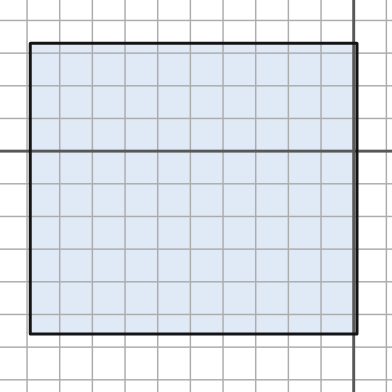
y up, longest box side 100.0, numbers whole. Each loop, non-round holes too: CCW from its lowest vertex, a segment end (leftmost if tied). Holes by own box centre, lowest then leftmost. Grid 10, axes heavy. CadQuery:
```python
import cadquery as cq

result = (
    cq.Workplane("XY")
    .moveTo(-99.0, -56.0)
    .lineTo(1.0, -56.0)
    .lineTo(1.0, 33.0)
    .lineTo(-99.0, 33.0)
    .close()
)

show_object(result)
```